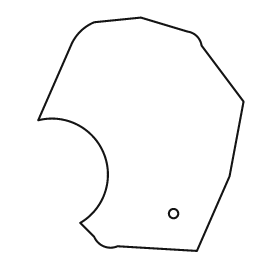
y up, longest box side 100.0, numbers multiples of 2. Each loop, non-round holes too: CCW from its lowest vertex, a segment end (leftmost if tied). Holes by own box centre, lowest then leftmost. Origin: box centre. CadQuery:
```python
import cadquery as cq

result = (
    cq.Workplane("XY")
    .moveTo(24.0, -50.0)
    .lineTo(38.0, -18.0)
    .lineTo(44.0, 14.0)
    .lineTo(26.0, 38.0)
    .threePointArc((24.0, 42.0), (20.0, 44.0))
    .lineTo(0.0, 50.0)
    .lineTo(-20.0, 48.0)
    .threePointArc((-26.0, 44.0), (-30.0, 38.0))
    .lineTo(-44.0, 6.0)
    .threePointArc((-16.0, -8.0), (-26.0, -38.0))
    .lineTo(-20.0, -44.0)
    .threePointArc((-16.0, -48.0), (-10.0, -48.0))
    .close()
    .moveTo(14.0, -34.0)
    .circle(2.0)
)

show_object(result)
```